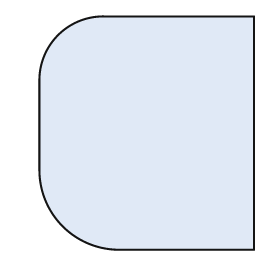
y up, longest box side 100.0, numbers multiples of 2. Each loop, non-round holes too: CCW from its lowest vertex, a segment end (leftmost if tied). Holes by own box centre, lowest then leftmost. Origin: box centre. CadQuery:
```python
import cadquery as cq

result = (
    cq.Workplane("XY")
    .moveTo(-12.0, -50.0)
    .lineTo(46.0, -50.0)
    .lineTo(46.0, 50.0)
    .lineTo(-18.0, 50.0)
    .threePointArc((-38.0, 42.0), (-46.0, 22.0))
    .lineTo(-46.0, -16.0)
    .threePointArc((-36.0, -40.0), (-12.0, -50.0))
    .close()
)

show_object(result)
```